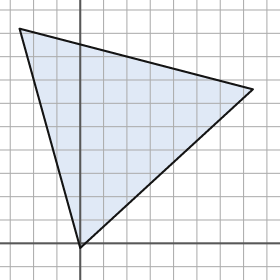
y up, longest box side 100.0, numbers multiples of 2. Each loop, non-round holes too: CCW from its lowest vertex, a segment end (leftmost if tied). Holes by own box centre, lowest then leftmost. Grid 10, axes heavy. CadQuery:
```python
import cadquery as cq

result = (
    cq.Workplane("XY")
    .moveTo(0.0, -2.0)
    .lineTo(74.0, 66.0)
    .lineTo(-26.0, 92.0)
    .close()
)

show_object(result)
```